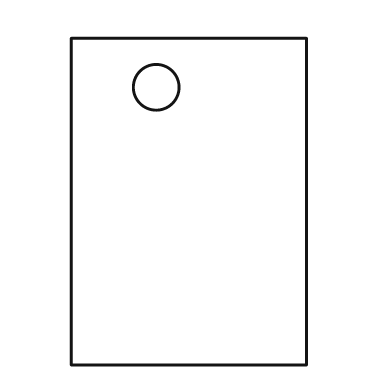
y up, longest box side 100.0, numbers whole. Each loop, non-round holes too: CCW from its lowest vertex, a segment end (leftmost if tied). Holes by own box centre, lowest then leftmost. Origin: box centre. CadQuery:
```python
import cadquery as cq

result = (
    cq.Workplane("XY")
    .moveTo(-36.0, -50.0)
    .lineTo(36.0, -50.0)
    .lineTo(36.0, 50.0)
    .lineTo(-36.0, 50.0)
    .close()
    .moveTo(-10.0, 35.0)
    .circle(7.0)
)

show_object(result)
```